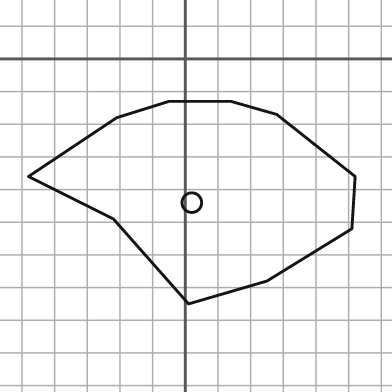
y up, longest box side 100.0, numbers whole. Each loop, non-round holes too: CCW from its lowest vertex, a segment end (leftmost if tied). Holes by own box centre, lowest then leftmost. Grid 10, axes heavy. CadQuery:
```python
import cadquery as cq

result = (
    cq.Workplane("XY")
    .moveTo(1.0, -75.0)
    .lineTo(25.0, -68.0)
    .lineTo(51.0, -52.0)
    .lineTo(52.0, -36.0)
    .lineTo(28.0, -17.0)
    .lineTo(14.0, -13.0)
    .lineTo(-5.0, -13.0)
    .lineTo(-21.0, -18.0)
    .lineTo(-48.0, -36.0)
    .lineTo(-22.0, -49.0)
    .close()
    .moveTo(2.0, -44.0)
    .circle(3.0)
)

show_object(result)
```